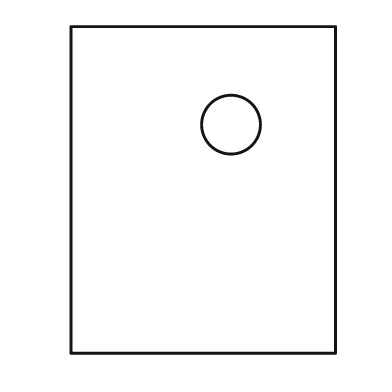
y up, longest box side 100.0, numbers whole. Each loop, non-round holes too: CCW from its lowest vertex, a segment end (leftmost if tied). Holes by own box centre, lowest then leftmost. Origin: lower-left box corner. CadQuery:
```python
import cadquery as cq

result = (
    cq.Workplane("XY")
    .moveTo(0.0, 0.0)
    .lineTo(81.0, 0.0)
    .lineTo(81.0, 100.0)
    .lineTo(0.0, 100.0)
    .close()
    .moveTo(49.0, 70.0)
    .circle(9.0)
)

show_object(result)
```